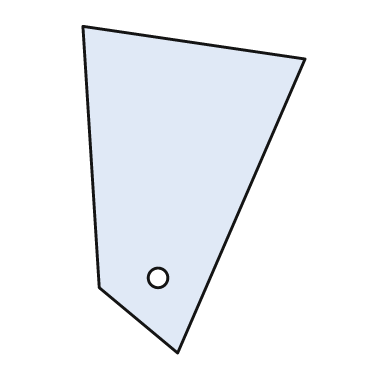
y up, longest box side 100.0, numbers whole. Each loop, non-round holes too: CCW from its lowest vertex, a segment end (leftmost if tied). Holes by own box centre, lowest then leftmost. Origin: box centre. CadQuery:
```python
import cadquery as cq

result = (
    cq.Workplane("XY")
    .moveTo(-5.0, -50.0)
    .lineTo(34.0, 40.0)
    .lineTo(-34.0, 50.0)
    .lineTo(-29.0, -30.0)
    .close()
    .moveTo(-11.0, -27.0)
    .circle(3.0)
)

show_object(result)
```